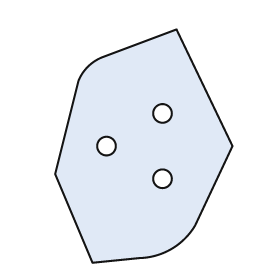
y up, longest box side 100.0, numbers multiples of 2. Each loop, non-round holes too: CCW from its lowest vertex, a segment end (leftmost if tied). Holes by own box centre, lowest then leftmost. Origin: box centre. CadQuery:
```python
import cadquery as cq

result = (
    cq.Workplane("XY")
    .moveTo(-22.0, -50.0)
    .lineTo(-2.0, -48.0)
    .threePointArc((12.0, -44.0), (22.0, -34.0))
    .lineTo(38.0, 0.0)
    .lineTo(14.0, 50.0)
    .lineTo(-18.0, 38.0)
    .threePointArc((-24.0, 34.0), (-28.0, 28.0))
    .lineTo(-38.0, -12.0)
    .close()
    .moveTo(8.0, -14.0)
    .circle(4.0)
    .moveTo(-16.0, 0.0)
    .circle(4.0)
    .moveTo(8.0, 14.0)
    .circle(4.0)
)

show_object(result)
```